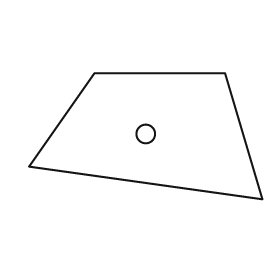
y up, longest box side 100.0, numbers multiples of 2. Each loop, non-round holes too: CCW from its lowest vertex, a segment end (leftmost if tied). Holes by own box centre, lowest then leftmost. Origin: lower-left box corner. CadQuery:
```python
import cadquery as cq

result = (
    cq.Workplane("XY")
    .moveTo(100.0, 0.0)
    .lineTo(84.0, 54.0)
    .lineTo(28.0, 54.0)
    .lineTo(0.0, 14.0)
    .close()
    .moveTo(50.0, 28.0)
    .circle(4.0)
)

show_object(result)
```